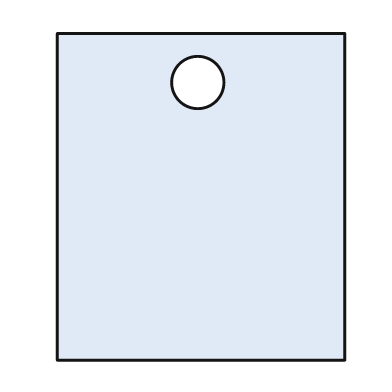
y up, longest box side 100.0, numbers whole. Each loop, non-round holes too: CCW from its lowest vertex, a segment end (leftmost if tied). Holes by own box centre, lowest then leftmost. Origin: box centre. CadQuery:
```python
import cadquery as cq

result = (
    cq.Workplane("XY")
    .moveTo(-44.0, -50.0)
    .lineTo(44.0, -50.0)
    .lineTo(44.0, 50.0)
    .lineTo(-44.0, 50.0)
    .close()
    .moveTo(-1.0, 35.0)
    .circle(8.0)
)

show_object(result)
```